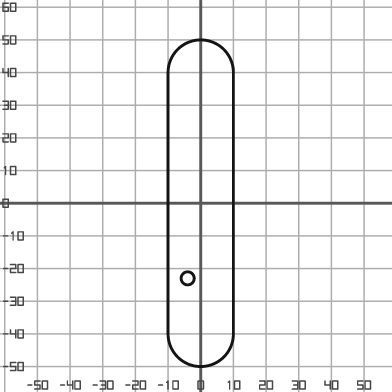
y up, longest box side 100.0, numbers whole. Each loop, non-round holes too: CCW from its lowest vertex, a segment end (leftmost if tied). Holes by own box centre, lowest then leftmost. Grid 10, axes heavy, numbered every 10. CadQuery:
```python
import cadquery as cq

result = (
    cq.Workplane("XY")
    .moveTo(-10.0, -40.0)
    .threePointArc((0.0, -50.0), (10.0, -40.0))
    .lineTo(10.0, 40.0)
    .threePointArc((0.0, 50.0), (-10.0, 40.0))
    .close()
    .moveTo(-4.0, -23.0)
    .circle(2.0)
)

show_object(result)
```